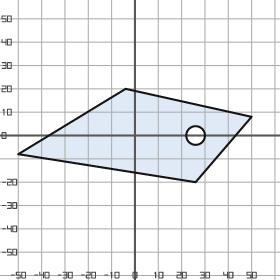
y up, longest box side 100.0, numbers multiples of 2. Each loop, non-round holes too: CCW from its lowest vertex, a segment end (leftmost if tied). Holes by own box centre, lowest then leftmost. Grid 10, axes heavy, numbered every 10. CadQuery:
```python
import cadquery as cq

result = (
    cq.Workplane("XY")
    .moveTo(26.0, -20.0)
    .lineTo(50.0, 8.0)
    .lineTo(-4.0, 20.0)
    .lineTo(-50.0, -8.0)
    .close()
    .moveTo(26.0, 0.0)
    .circle(4.0)
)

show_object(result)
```